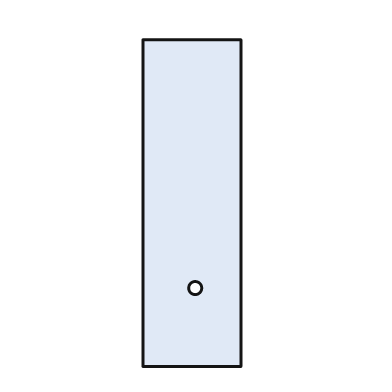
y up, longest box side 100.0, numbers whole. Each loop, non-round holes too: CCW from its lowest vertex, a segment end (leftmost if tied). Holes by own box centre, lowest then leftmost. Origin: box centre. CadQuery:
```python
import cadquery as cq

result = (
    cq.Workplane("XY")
    .moveTo(-15.0, -50.0)
    .lineTo(15.0, -50.0)
    .lineTo(15.0, 50.0)
    .lineTo(-15.0, 50.0)
    .close()
    .moveTo(1.0, -26.0)
    .circle(2.0)
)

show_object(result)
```